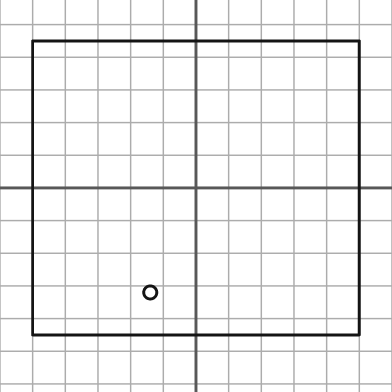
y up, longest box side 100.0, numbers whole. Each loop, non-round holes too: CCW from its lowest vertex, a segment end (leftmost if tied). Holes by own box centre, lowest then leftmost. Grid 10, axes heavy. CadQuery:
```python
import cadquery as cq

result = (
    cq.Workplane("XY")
    .moveTo(-50.0, -45.0)
    .lineTo(50.0, -45.0)
    .lineTo(50.0, 45.0)
    .lineTo(-50.0, 45.0)
    .close()
    .moveTo(-14.0, -32.0)
    .circle(2.0)
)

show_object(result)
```